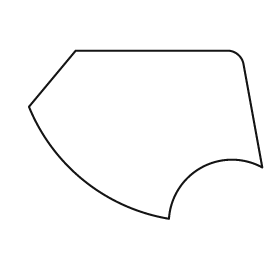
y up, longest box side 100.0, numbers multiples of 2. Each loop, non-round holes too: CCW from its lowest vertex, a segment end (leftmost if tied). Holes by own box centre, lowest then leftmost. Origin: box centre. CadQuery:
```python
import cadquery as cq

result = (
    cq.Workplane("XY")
    .moveTo(10.0, -36.0)
    .threePointArc((24.0, -14.0), (50.0, -14.0))
    .lineTo(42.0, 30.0)
    .threePointArc((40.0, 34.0), (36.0, 36.0))
    .lineTo(-30.0, 36.0)
    .lineTo(-50.0, 12.0)
    .threePointArc((-26.0, -20.0), (10.0, -36.0))
    .close()
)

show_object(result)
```